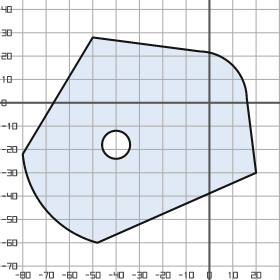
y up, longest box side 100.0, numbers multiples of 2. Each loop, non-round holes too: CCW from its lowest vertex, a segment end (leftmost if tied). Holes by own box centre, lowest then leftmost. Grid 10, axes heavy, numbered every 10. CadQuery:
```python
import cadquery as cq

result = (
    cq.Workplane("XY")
    .moveTo(-48.0, -60.0)
    .lineTo(20.0, -30.0)
    .lineTo(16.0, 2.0)
    .threePointArc((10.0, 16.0), (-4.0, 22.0))
    .lineTo(-50.0, 28.0)
    .lineTo(-80.0, -22.0)
    .threePointArc((-70.0, -46.0), (-48.0, -60.0))
    .close()
    .moveTo(-40.0, -18.0)
    .circle(6.0)
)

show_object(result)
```